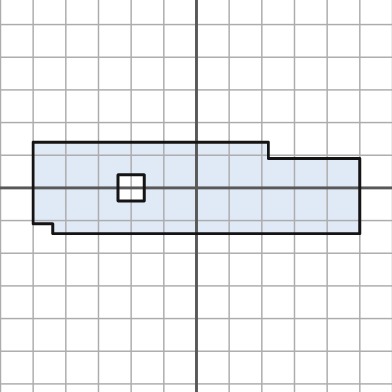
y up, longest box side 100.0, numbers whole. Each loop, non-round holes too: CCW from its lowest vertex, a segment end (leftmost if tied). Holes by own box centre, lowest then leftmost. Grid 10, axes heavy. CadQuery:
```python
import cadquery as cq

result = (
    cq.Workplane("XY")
    .moveTo(-44.0, -14.0)
    .lineTo(50.0, -14.0)
    .lineTo(50.0, 9.0)
    .lineTo(22.0, 9.0)
    .lineTo(22.0, 14.0)
    .lineTo(-50.0, 14.0)
    .lineTo(-50.0, -11.0)
    .lineTo(-44.0, -11.0)
    .close()
    .moveTo(-24.0, -4.0)
    .lineTo(-16.0, -4.0)
    .lineTo(-16.0, 4.0)
    .lineTo(-24.0, 4.0)
    .close()
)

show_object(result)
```